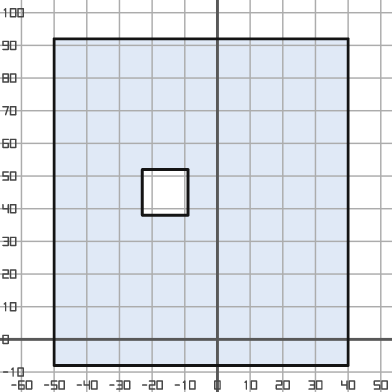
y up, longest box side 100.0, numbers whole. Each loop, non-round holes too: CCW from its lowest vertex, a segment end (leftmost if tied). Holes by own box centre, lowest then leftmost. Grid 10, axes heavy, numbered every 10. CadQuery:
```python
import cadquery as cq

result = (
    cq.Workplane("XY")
    .moveTo(-50.0, -8.0)
    .lineTo(40.0, -8.0)
    .lineTo(40.0, 92.0)
    .lineTo(-50.0, 92.0)
    .close()
    .moveTo(-23.0, 38.0)
    .lineTo(-9.0, 38.0)
    .lineTo(-9.0, 52.0)
    .lineTo(-23.0, 52.0)
    .close()
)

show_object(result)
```